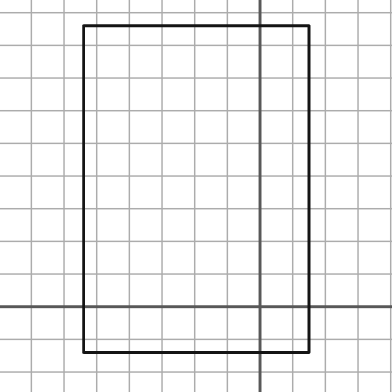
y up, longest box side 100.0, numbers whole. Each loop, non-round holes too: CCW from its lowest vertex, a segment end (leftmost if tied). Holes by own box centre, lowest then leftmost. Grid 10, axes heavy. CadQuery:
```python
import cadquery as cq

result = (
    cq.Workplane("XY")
    .moveTo(-54.0, -14.0)
    .lineTo(15.0, -14.0)
    .lineTo(15.0, 86.0)
    .lineTo(-54.0, 86.0)
    .close()
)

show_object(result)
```